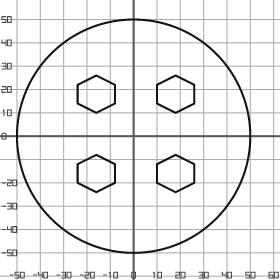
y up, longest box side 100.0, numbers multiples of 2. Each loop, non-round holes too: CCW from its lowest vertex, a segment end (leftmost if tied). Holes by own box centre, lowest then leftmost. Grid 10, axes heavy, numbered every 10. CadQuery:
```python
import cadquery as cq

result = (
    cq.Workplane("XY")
    .moveTo(0.0, 0.0)
    .circle(50.0)
    .moveTo(-16.0, -24.0)
    .lineTo(-8.0, -20.0)
    .lineTo(-8.0, -12.0)
    .lineTo(-16.0, -8.0)
    .lineTo(-24.0, -12.0)
    .lineTo(-24.0, -20.0)
    .close()
    .moveTo(18.0, -24.0)
    .lineTo(26.0, -20.0)
    .lineTo(26.0, -12.0)
    .lineTo(18.0, -8.0)
    .lineTo(10.0, -12.0)
    .lineTo(10.0, -20.0)
    .close()
    .moveTo(-16.0, 10.0)
    .lineTo(-8.0, 14.0)
    .lineTo(-8.0, 22.0)
    .lineTo(-16.0, 26.0)
    .lineTo(-24.0, 22.0)
    .lineTo(-24.0, 14.0)
    .close()
    .moveTo(18.0, 10.0)
    .lineTo(26.0, 14.0)
    .lineTo(26.0, 22.0)
    .lineTo(18.0, 26.0)
    .lineTo(10.0, 22.0)
    .lineTo(10.0, 14.0)
    .close()
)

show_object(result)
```